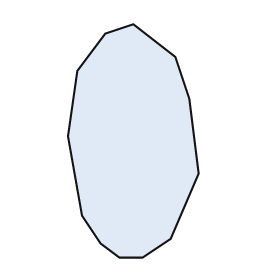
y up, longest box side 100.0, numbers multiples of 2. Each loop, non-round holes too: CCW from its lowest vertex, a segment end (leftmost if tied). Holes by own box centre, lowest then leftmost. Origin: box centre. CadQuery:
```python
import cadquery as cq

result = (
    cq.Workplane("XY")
    .moveTo(-6.0, -50.0)
    .lineTo(4.0, -50.0)
    .lineTo(16.0, -42.0)
    .lineTo(28.0, -14.0)
    .lineTo(24.0, 18.0)
    .lineTo(18.0, 36.0)
    .lineTo(0.0, 50.0)
    .lineTo(-12.0, 46.0)
    .lineTo(-24.0, 30.0)
    .lineTo(-28.0, 2.0)
    .lineTo(-22.0, -32.0)
    .lineTo(-14.0, -44.0)
    .close()
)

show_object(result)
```